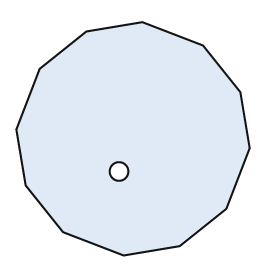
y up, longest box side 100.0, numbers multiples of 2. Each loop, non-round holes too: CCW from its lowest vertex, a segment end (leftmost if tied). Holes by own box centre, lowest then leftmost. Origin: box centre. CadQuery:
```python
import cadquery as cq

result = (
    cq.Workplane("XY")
    .moveTo(-4.0, -50.0)
    .lineTo(20.0, -46.0)
    .lineTo(40.0, -30.0)
    .lineTo(50.0, -4.0)
    .lineTo(46.0, 20.0)
    .lineTo(30.0, 40.0)
    .lineTo(4.0, 50.0)
    .lineTo(-20.0, 46.0)
    .lineTo(-40.0, 30.0)
    .lineTo(-50.0, 4.0)
    .lineTo(-46.0, -20.0)
    .lineTo(-30.0, -40.0)
    .close()
    .moveTo(-6.0, -14.0)
    .circle(4.0)
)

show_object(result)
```